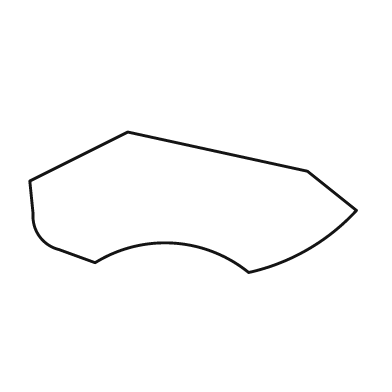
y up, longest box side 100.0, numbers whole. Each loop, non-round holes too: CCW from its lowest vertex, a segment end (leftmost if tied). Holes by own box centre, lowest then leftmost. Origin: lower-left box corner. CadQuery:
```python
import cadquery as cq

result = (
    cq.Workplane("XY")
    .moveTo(67.0, 0.0)
    .threePointArc((85.0, 7.0), (100.0, 19.0))
    .lineTo(85.0, 31.0)
    .lineTo(30.0, 43.0)
    .lineTo(0.0, 28.0)
    .lineTo(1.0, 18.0)
    .threePointArc((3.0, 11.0), (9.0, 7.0))
    .lineTo(20.0, 3.0)
    .threePointArc((44.0, 9.0), (67.0, 0.0))
    .close()
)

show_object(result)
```